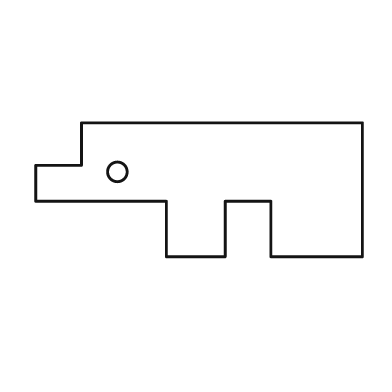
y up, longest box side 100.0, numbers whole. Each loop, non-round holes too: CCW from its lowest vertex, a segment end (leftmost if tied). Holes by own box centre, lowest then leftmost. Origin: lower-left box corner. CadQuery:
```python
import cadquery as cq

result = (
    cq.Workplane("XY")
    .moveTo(40.0, 0.0)
    .lineTo(58.0, 0.0)
    .lineTo(58.0, 17.0)
    .lineTo(72.0, 17.0)
    .lineTo(72.0, 0.0)
    .lineTo(100.0, 0.0)
    .lineTo(100.0, 41.0)
    .lineTo(14.0, 41.0)
    .lineTo(14.0, 28.0)
    .lineTo(0.0, 28.0)
    .lineTo(0.0, 17.0)
    .lineTo(40.0, 17.0)
    .close()
    .moveTo(25.0, 26.0)
    .circle(3.0)
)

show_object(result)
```